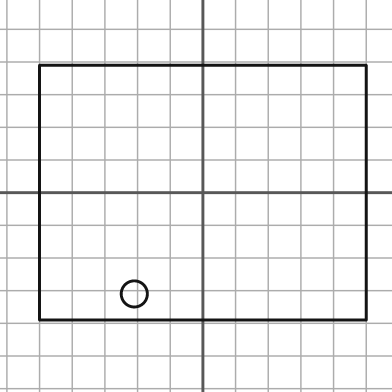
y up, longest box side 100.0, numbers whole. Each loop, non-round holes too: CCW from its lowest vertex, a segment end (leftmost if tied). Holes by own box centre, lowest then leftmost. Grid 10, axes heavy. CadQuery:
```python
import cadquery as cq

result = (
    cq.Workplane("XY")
    .moveTo(-50.0, -39.0)
    .lineTo(50.0, -39.0)
    .lineTo(50.0, 39.0)
    .lineTo(-50.0, 39.0)
    .close()
    .moveTo(-21.0, -31.0)
    .circle(4.0)
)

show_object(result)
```